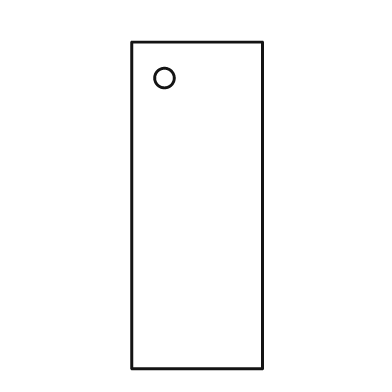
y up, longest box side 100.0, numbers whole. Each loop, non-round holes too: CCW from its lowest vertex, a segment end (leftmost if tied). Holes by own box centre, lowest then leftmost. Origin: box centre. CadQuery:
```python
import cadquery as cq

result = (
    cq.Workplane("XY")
    .moveTo(-20.0, -50.0)
    .lineTo(20.0, -50.0)
    .lineTo(20.0, 50.0)
    .lineTo(-20.0, 50.0)
    .close()
    .moveTo(-10.0, 39.0)
    .circle(3.0)
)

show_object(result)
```